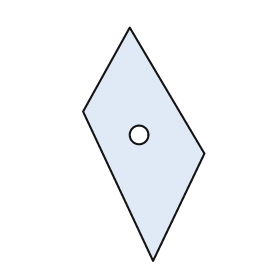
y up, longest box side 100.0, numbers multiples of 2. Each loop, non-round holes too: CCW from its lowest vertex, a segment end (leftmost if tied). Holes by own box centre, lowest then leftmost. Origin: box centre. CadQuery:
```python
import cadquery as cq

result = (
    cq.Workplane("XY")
    .moveTo(4.0, -50.0)
    .lineTo(26.0, -4.0)
    .lineTo(-6.0, 50.0)
    .lineTo(-26.0, 14.0)
    .close()
    .moveTo(-2.0, 4.0)
    .circle(4.0)
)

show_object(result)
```